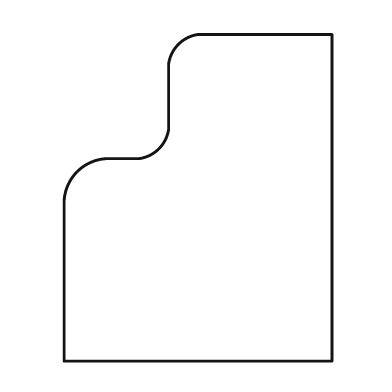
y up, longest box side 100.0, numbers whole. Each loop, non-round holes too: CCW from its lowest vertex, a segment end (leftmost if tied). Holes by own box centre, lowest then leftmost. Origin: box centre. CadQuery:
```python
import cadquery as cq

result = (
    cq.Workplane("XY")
    .moveTo(-41.0, -50.0)
    .lineTo(41.0, -50.0)
    .lineTo(41.0, 50.0)
    .lineTo(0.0, 50.0)
    .threePointArc((-6.0, 47.0), (-9.0, 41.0))
    .lineTo(-9.0, 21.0)
    .threePointArc((-12.0, 15.0), (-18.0, 12.0))
    .lineTo(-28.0, 12.0)
    .threePointArc((-37.0, 8.0), (-41.0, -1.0))
    .close()
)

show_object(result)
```